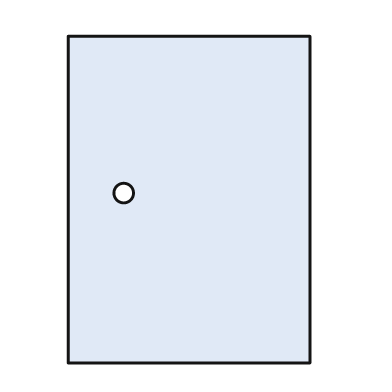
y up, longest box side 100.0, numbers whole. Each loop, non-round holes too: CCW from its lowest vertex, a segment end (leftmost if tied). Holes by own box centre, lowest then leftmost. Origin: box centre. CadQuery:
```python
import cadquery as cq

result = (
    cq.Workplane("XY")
    .moveTo(-37.0, -50.0)
    .lineTo(37.0, -50.0)
    .lineTo(37.0, 50.0)
    .lineTo(-37.0, 50.0)
    .close()
    .moveTo(-20.0, 2.0)
    .circle(3.0)
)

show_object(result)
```